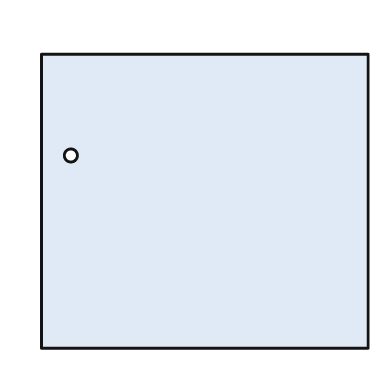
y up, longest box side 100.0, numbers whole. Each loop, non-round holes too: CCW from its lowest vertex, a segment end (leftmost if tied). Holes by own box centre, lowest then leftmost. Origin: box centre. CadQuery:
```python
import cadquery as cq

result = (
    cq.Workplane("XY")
    .moveTo(-50.0, -45.0)
    .lineTo(50.0, -45.0)
    .lineTo(50.0, 45.0)
    .lineTo(-50.0, 45.0)
    .close()
    .moveTo(-41.0, 14.0)
    .circle(2.0)
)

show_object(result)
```